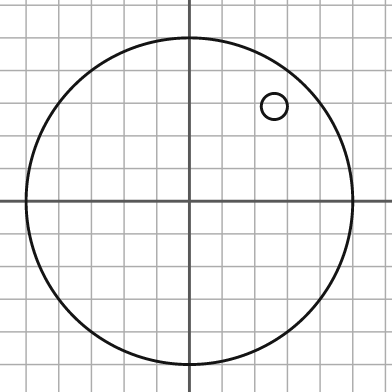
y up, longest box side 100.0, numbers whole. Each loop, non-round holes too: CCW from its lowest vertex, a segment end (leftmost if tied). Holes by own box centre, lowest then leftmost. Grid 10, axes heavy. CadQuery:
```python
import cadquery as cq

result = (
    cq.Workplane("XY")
    .moveTo(0.0, 0.0)
    .circle(50.0)
    .moveTo(26.0, 29.0)
    .circle(4.0)
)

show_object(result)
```